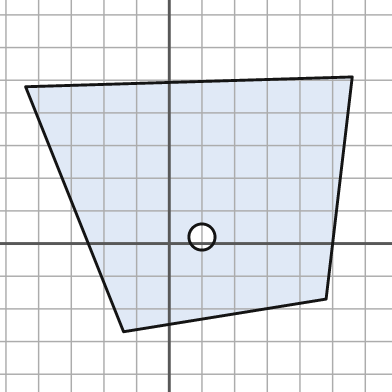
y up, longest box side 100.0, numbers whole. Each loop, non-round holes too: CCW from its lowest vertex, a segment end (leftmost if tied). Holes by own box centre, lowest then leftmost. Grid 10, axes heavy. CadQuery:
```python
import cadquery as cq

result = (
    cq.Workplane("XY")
    .moveTo(-14.0, -27.0)
    .lineTo(48.0, -17.0)
    .lineTo(56.0, 51.0)
    .lineTo(-44.0, 48.0)
    .close()
    .moveTo(10.0, 2.0)
    .circle(4.0)
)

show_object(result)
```